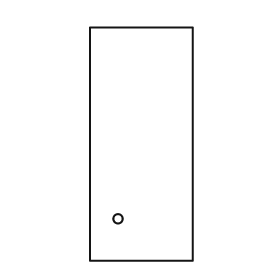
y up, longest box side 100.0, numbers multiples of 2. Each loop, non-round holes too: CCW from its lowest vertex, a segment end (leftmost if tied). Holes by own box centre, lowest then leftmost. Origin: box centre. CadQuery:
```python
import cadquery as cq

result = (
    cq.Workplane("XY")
    .moveTo(-22.0, -50.0)
    .lineTo(22.0, -50.0)
    .lineTo(22.0, 50.0)
    .lineTo(-22.0, 50.0)
    .close()
    .moveTo(-10.0, -32.0)
    .circle(2.0)
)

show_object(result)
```